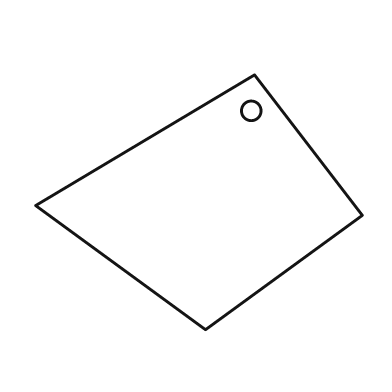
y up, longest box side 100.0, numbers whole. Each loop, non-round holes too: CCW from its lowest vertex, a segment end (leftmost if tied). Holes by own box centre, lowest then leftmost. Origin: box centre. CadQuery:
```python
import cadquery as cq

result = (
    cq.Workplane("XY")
    .moveTo(2.0, -39.0)
    .lineTo(50.0, -4.0)
    .lineTo(17.0, 39.0)
    .lineTo(-50.0, -1.0)
    .close()
    .moveTo(16.0, 28.0)
    .circle(3.0)
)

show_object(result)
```